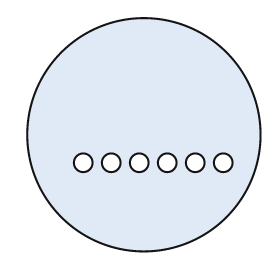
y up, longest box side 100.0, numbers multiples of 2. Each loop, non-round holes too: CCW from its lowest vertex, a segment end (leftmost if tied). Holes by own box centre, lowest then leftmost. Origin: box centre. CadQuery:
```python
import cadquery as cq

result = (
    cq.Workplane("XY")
    .moveTo(0.0, 0.0)
    .circle(50.0)
    .moveTo(-26.0, -12.0)
    .circle(4.0)
    .moveTo(-14.0, -12.0)
    .circle(4.0)
    .moveTo(-2.0, -12.0)
    .circle(4.0)
    .moveTo(10.0, -12.0)
    .circle(4.0)
    .moveTo(22.0, -12.0)
    .circle(4.0)
    .moveTo(34.0, -12.0)
    .circle(4.0)
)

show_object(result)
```